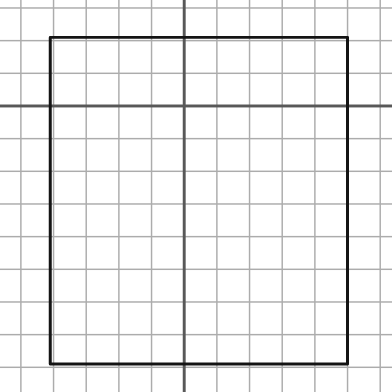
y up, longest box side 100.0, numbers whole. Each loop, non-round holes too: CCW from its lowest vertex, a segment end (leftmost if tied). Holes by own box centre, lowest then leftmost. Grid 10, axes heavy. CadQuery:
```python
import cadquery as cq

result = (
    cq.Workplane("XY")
    .moveTo(-41.0, -79.0)
    .lineTo(50.0, -79.0)
    .lineTo(50.0, 21.0)
    .lineTo(-41.0, 21.0)
    .close()
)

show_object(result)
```